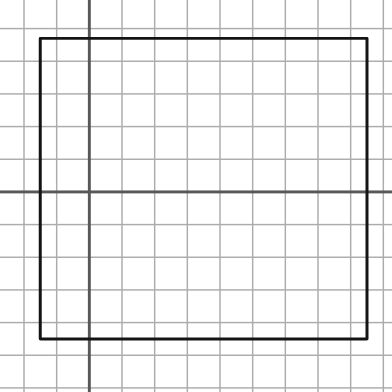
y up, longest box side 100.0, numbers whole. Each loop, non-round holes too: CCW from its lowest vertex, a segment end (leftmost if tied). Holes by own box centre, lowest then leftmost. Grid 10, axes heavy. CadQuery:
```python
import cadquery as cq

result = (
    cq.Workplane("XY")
    .moveTo(-15.0, -45.0)
    .lineTo(85.0, -45.0)
    .lineTo(85.0, 47.0)
    .lineTo(-15.0, 47.0)
    .close()
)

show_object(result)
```